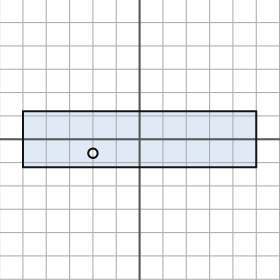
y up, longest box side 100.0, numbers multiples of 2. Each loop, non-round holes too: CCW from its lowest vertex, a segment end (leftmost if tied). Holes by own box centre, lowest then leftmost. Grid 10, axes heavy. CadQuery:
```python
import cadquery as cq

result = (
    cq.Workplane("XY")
    .moveTo(-50.0, -12.0)
    .lineTo(50.0, -12.0)
    .lineTo(50.0, 12.0)
    .lineTo(-50.0, 12.0)
    .close()
    .moveTo(-20.0, -6.0)
    .circle(2.0)
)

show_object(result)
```